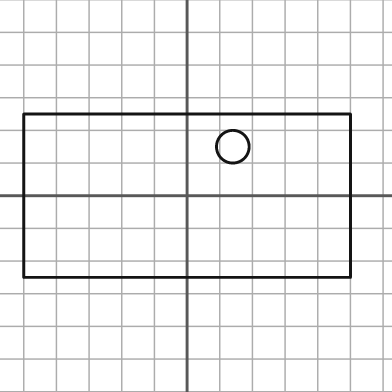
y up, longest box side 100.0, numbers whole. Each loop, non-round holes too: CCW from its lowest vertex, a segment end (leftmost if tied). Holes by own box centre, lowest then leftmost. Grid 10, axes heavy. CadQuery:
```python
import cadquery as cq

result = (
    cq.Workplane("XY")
    .moveTo(-50.0, -25.0)
    .lineTo(50.0, -25.0)
    .lineTo(50.0, 25.0)
    .lineTo(-50.0, 25.0)
    .close()
    .moveTo(14.0, 15.0)
    .circle(5.0)
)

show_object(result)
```